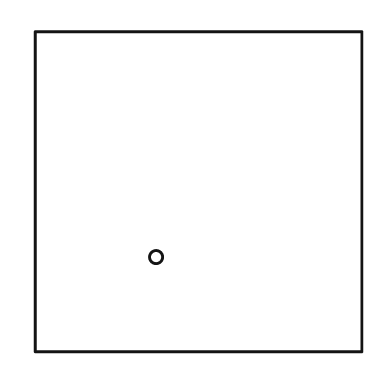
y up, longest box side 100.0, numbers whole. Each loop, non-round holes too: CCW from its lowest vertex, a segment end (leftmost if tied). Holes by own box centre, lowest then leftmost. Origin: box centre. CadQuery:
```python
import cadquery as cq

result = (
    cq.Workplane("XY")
    .moveTo(-50.0, -49.0)
    .lineTo(50.0, -49.0)
    .lineTo(50.0, 49.0)
    .lineTo(-50.0, 49.0)
    .close()
    .moveTo(-13.0, -20.0)
    .circle(2.0)
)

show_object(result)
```